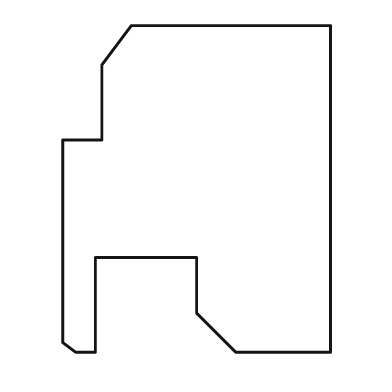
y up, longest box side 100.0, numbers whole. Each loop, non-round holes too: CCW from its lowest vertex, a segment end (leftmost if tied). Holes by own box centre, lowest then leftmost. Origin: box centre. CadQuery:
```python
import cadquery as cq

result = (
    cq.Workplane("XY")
    .moveTo(-37.0, -50.0)
    .lineTo(-31.0, -50.0)
    .lineTo(-31.0, -21.0)
    .lineTo(0.0, -21.0)
    .lineTo(0.0, -38.0)
    .lineTo(12.0, -50.0)
    .lineTo(41.0, -50.0)
    .lineTo(41.0, 50.0)
    .lineTo(-20.0, 50.0)
    .lineTo(-29.0, 38.0)
    .lineTo(-29.0, 15.0)
    .lineTo(-41.0, 15.0)
    .lineTo(-41.0, -47.0)
    .close()
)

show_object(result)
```